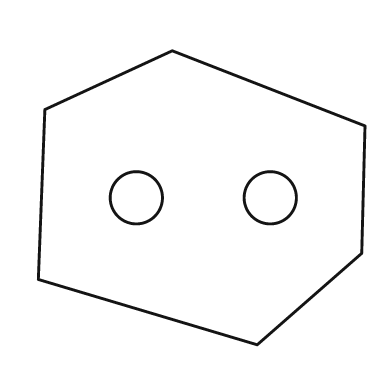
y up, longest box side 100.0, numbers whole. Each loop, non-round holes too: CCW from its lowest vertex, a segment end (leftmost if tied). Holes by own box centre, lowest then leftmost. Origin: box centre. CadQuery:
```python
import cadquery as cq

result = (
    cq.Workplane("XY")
    .moveTo(17.0, -45.0)
    .lineTo(49.0, -17.0)
    .lineTo(50.0, 22.0)
    .lineTo(-9.0, 45.0)
    .lineTo(-48.0, 27.0)
    .lineTo(-50.0, -25.0)
    .close()
    .moveTo(-20.0, 0.0)
    .circle(8.0)
    .moveTo(21.0, 0.0)
    .circle(8.0)
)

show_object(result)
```